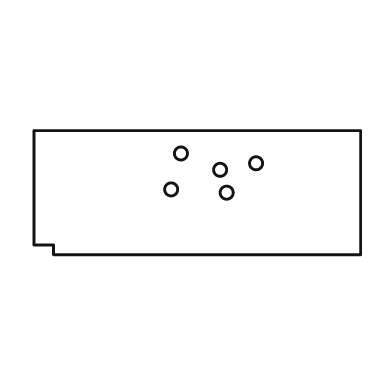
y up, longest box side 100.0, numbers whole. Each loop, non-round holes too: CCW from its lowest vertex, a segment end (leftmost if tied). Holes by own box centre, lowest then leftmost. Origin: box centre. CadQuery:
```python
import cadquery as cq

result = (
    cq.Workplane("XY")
    .moveTo(-44.0, -19.0)
    .lineTo(50.0, -19.0)
    .lineTo(50.0, 19.0)
    .lineTo(-50.0, 19.0)
    .lineTo(-50.0, -16.0)
    .lineTo(-44.0, -16.0)
    .close()
    .moveTo(9.0, 0.0)
    .circle(2.0)
    .moveTo(-8.0, 1.0)
    .circle(2.0)
    .moveTo(7.0, 7.0)
    .circle(2.0)
    .moveTo(18.0, 9.0)
    .circle(2.0)
    .moveTo(-5.0, 12.0)
    .circle(2.0)
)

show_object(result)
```